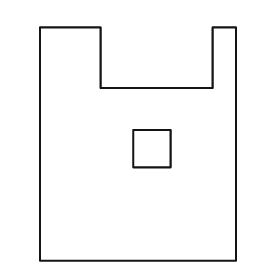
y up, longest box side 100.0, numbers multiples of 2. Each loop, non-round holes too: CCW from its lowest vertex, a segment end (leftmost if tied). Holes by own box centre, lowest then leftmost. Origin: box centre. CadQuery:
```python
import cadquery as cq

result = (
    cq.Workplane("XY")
    .moveTo(-42.0, -50.0)
    .lineTo(42.0, -50.0)
    .lineTo(42.0, 50.0)
    .lineTo(32.0, 50.0)
    .lineTo(32.0, 24.0)
    .lineTo(-16.0, 24.0)
    .lineTo(-16.0, 50.0)
    .lineTo(-42.0, 50.0)
    .close()
    .moveTo(-2.0, -10.0)
    .lineTo(14.0, -10.0)
    .lineTo(14.0, 6.0)
    .lineTo(-2.0, 6.0)
    .close()
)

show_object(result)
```